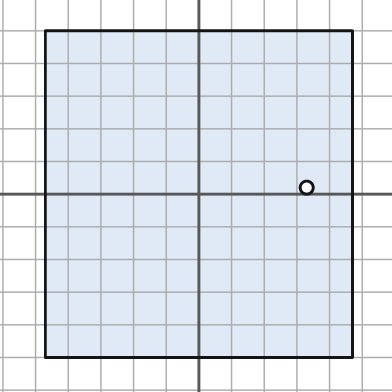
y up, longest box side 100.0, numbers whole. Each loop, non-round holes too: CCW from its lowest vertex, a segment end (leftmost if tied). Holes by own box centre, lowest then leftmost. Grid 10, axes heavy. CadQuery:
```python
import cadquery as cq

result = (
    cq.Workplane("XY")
    .moveTo(-47.0, -50.0)
    .lineTo(47.0, -50.0)
    .lineTo(47.0, 50.0)
    .lineTo(-47.0, 50.0)
    .close()
    .moveTo(33.0, 2.0)
    .circle(2.0)
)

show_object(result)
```